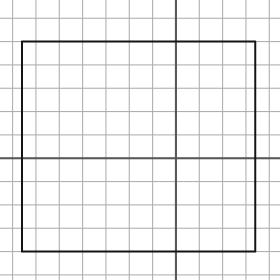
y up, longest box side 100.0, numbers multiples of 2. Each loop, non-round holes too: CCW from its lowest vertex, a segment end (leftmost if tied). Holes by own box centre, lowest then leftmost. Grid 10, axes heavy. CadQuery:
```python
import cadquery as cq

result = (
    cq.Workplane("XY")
    .moveTo(-66.0, -40.0)
    .lineTo(34.0, -40.0)
    .lineTo(34.0, 50.0)
    .lineTo(-66.0, 50.0)
    .close()
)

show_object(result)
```